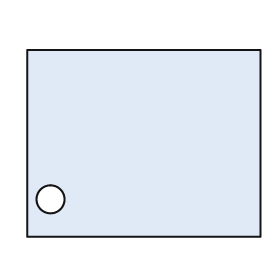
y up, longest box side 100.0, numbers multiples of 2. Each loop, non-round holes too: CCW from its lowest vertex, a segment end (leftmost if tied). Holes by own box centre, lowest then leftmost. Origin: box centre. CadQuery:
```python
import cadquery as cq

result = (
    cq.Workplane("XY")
    .moveTo(-50.0, -40.0)
    .lineTo(50.0, -40.0)
    .lineTo(50.0, 40.0)
    .lineTo(-50.0, 40.0)
    .close()
    .moveTo(-40.0, -24.0)
    .circle(6.0)
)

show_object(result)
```